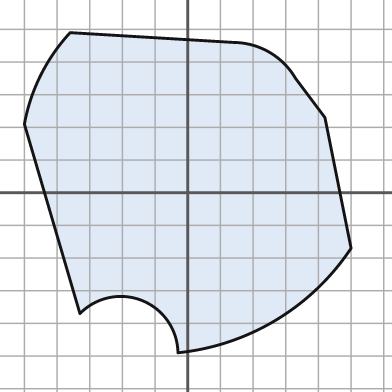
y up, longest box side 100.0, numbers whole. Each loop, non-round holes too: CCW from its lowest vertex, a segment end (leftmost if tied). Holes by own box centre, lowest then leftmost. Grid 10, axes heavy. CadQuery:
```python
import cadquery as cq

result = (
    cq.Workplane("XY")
    .moveTo(-3.0, -49.0)
    .threePointArc((27.0, -39.0), (50.0, -17.0))
    .lineTo(42.0, 23.0)
    .lineTo(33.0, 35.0)
    .threePointArc((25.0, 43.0), (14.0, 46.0))
    .lineTo(-36.0, 49.0)
    .threePointArc((-45.0, 36.0), (-50.0, 21.0))
    .lineTo(-33.0, -37.0)
    .threePointArc((-14.0, -33.0), (-3.0, -49.0))
    .close()
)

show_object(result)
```